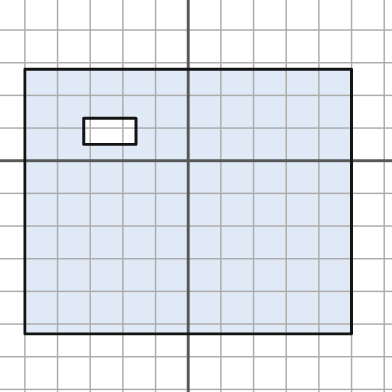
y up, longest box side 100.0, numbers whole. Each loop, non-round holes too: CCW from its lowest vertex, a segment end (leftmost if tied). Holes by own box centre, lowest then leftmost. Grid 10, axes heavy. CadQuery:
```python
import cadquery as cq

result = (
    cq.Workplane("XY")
    .moveTo(-50.0, -53.0)
    .lineTo(50.0, -53.0)
    .lineTo(50.0, 28.0)
    .lineTo(-50.0, 28.0)
    .close()
    .moveTo(-32.0, 5.0)
    .lineTo(-16.0, 5.0)
    .lineTo(-16.0, 13.0)
    .lineTo(-32.0, 13.0)
    .close()
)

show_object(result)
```